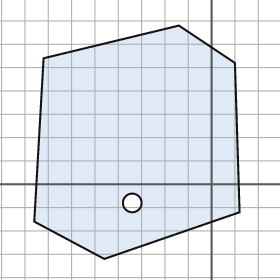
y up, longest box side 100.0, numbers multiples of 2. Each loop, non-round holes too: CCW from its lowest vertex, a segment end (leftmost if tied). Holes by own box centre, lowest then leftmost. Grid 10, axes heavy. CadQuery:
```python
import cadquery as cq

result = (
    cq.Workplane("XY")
    .moveTo(-46.0, -32.0)
    .lineTo(12.0, -12.0)
    .lineTo(10.0, 52.0)
    .lineTo(-14.0, 68.0)
    .lineTo(-72.0, 54.0)
    .lineTo(-76.0, -16.0)
    .close()
    .moveTo(-34.0, -8.0)
    .circle(4.0)
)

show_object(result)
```